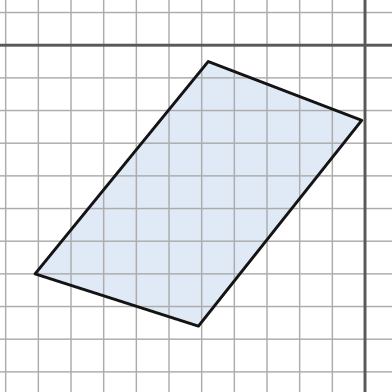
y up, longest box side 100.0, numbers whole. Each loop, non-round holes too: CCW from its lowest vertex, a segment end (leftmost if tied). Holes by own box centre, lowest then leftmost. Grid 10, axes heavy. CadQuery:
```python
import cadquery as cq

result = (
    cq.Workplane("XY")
    .moveTo(-51.0, -86.0)
    .lineTo(-1.0, -23.0)
    .lineTo(-48.0, -5.0)
    .lineTo(-101.0, -70.0)
    .close()
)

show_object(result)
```